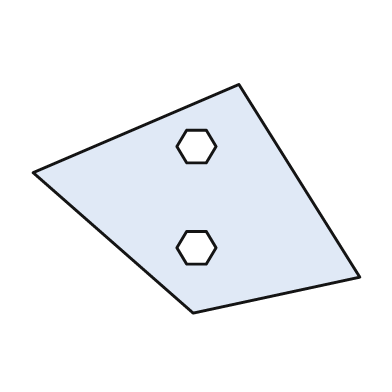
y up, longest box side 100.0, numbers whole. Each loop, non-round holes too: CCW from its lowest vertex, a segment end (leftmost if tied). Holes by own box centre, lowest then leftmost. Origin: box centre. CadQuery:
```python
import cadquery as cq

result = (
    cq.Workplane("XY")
    .moveTo(-1.0, -35.0)
    .lineTo(50.0, -24.0)
    .lineTo(13.0, 35.0)
    .lineTo(-50.0, 8.0)
    .close()
    .moveTo(-3.0, -20.0)
    .lineTo(3.0, -20.0)
    .lineTo(6.0, -15.0)
    .lineTo(3.0, -10.0)
    .lineTo(-3.0, -10.0)
    .lineTo(-6.0, -15.0)
    .close()
    .moveTo(-3.0, 11.0)
    .lineTo(3.0, 11.0)
    .lineTo(6.0, 16.0)
    .lineTo(3.0, 21.0)
    .lineTo(-3.0, 21.0)
    .lineTo(-6.0, 16.0)
    .close()
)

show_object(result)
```